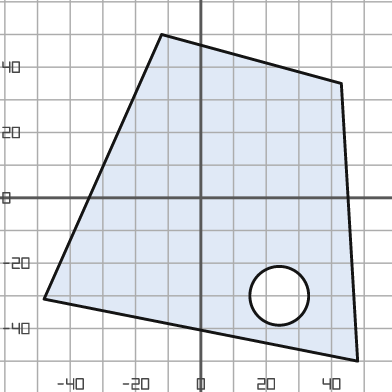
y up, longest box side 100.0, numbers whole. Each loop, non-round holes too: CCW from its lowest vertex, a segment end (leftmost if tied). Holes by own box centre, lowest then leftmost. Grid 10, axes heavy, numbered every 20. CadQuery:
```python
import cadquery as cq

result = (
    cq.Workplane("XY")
    .moveTo(48.0, -50.0)
    .lineTo(43.0, 35.0)
    .lineTo(-12.0, 50.0)
    .lineTo(-48.0, -31.0)
    .close()
    .moveTo(24.0, -30.0)
    .circle(9.0)
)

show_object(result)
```